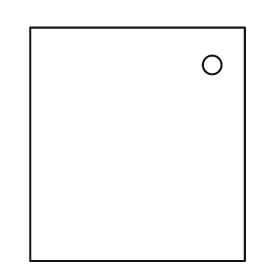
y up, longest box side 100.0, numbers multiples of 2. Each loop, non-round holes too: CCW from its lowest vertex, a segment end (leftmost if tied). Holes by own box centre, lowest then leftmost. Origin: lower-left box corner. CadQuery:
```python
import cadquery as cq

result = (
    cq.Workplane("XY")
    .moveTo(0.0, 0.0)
    .lineTo(92.0, 0.0)
    .lineTo(92.0, 100.0)
    .lineTo(0.0, 100.0)
    .close()
    .moveTo(78.0, 84.0)
    .circle(4.0)
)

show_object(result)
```